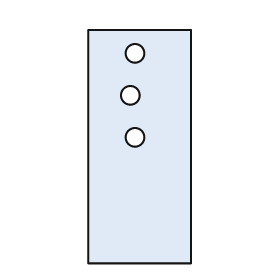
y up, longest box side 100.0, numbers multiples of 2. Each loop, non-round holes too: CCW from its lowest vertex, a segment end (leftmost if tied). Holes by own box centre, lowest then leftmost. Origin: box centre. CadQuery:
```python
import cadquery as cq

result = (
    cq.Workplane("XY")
    .moveTo(-22.0, -50.0)
    .lineTo(22.0, -50.0)
    .lineTo(22.0, 50.0)
    .lineTo(-22.0, 50.0)
    .close()
    .moveTo(-2.0, 4.0)
    .circle(4.0)
    .moveTo(-4.0, 22.0)
    .circle(4.0)
    .moveTo(-2.0, 40.0)
    .circle(4.0)
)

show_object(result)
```